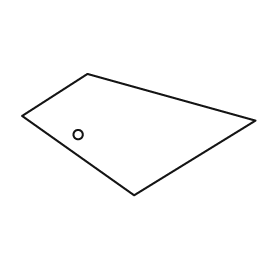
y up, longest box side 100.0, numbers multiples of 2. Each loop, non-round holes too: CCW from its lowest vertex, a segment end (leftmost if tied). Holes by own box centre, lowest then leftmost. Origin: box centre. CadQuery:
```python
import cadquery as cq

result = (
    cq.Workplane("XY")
    .moveTo(-2.0, -26.0)
    .lineTo(50.0, 6.0)
    .lineTo(-22.0, 26.0)
    .lineTo(-50.0, 8.0)
    .close()
    .moveTo(-26.0, 0.0)
    .circle(2.0)
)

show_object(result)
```